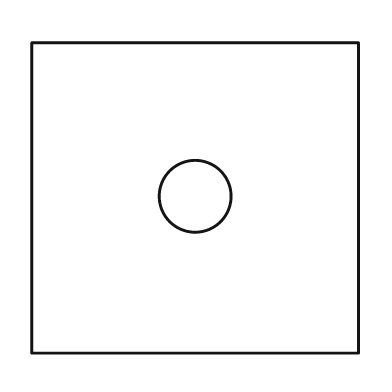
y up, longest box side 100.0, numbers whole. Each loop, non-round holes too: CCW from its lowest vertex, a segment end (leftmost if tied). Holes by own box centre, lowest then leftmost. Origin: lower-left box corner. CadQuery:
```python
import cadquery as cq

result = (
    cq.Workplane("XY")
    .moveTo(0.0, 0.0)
    .lineTo(100.0, 0.0)
    .lineTo(100.0, 95.0)
    .lineTo(0.0, 95.0)
    .close()
    .moveTo(50.0, 48.0)
    .circle(11.0)
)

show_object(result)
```